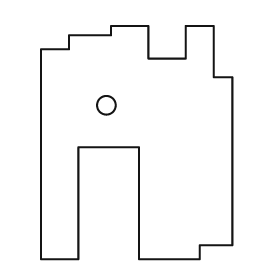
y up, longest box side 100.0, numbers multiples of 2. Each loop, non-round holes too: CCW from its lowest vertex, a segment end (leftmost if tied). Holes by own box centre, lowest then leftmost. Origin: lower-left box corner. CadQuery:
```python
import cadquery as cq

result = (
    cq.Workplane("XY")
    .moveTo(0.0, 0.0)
    .lineTo(16.0, 0.0)
    .lineTo(16.0, 48.0)
    .lineTo(42.0, 48.0)
    .lineTo(42.0, 0.0)
    .lineTo(68.0, 0.0)
    .lineTo(68.0, 6.0)
    .lineTo(82.0, 6.0)
    .lineTo(82.0, 78.0)
    .lineTo(74.0, 78.0)
    .lineTo(74.0, 100.0)
    .lineTo(62.0, 100.0)
    .lineTo(62.0, 86.0)
    .lineTo(46.0, 86.0)
    .lineTo(46.0, 100.0)
    .lineTo(30.0, 100.0)
    .lineTo(30.0, 96.0)
    .lineTo(12.0, 96.0)
    .lineTo(12.0, 90.0)
    .lineTo(0.0, 90.0)
    .close()
    .moveTo(28.0, 66.0)
    .circle(4.0)
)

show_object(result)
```